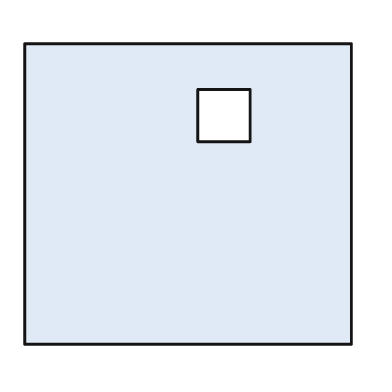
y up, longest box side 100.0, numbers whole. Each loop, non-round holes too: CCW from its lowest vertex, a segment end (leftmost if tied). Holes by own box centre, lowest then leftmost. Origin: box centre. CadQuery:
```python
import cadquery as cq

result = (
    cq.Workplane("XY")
    .moveTo(-50.0, -46.0)
    .lineTo(50.0, -46.0)
    .lineTo(50.0, 46.0)
    .lineTo(-50.0, 46.0)
    .close()
    .moveTo(3.0, 16.0)
    .lineTo(19.0, 16.0)
    .lineTo(19.0, 32.0)
    .lineTo(3.0, 32.0)
    .close()
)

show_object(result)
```